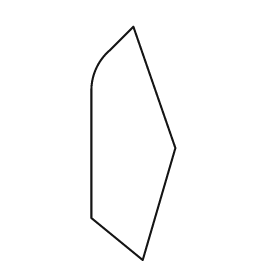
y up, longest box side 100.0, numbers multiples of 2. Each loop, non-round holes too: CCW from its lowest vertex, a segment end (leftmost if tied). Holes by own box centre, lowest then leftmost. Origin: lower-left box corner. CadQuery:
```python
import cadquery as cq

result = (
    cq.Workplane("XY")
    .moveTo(22.0, 0.0)
    .lineTo(36.0, 48.0)
    .lineTo(18.0, 100.0)
    .lineTo(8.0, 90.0)
    .threePointArc((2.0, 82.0), (0.0, 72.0))
    .lineTo(0.0, 18.0)
    .close()
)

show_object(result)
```